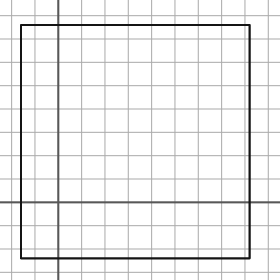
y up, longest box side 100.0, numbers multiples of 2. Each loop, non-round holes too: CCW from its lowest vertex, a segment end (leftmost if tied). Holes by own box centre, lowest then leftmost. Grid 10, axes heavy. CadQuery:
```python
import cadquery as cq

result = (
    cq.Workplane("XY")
    .moveTo(-16.0, -24.0)
    .lineTo(82.0, -24.0)
    .lineTo(82.0, 76.0)
    .lineTo(-16.0, 76.0)
    .close()
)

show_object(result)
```